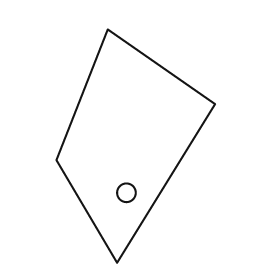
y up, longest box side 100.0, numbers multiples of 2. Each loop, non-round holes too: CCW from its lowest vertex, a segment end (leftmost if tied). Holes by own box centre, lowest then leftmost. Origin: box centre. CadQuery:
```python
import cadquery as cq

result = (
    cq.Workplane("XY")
    .moveTo(-8.0, -50.0)
    .lineTo(34.0, 18.0)
    .lineTo(-12.0, 50.0)
    .lineTo(-34.0, -6.0)
    .close()
    .moveTo(-4.0, -20.0)
    .circle(4.0)
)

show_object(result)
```